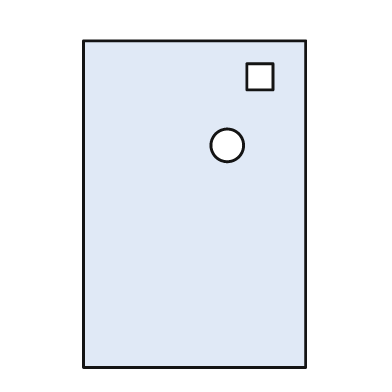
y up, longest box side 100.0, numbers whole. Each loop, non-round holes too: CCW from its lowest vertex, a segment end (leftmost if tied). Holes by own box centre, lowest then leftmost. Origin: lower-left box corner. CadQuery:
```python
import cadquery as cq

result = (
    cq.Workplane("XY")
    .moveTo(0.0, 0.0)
    .lineTo(68.0, 0.0)
    .lineTo(68.0, 100.0)
    .lineTo(0.0, 100.0)
    .close()
    .moveTo(44.0, 68.0)
    .circle(5.0)
    .moveTo(50.0, 85.0)
    .lineTo(58.0, 85.0)
    .lineTo(58.0, 93.0)
    .lineTo(50.0, 93.0)
    .close()
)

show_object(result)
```